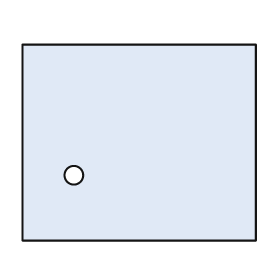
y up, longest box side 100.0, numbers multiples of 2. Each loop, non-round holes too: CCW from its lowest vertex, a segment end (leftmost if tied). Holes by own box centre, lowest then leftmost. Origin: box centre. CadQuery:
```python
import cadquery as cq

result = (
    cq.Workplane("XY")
    .moveTo(-50.0, -42.0)
    .lineTo(50.0, -42.0)
    .lineTo(50.0, 42.0)
    .lineTo(-50.0, 42.0)
    .close()
    .moveTo(-28.0, -14.0)
    .circle(4.0)
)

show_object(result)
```